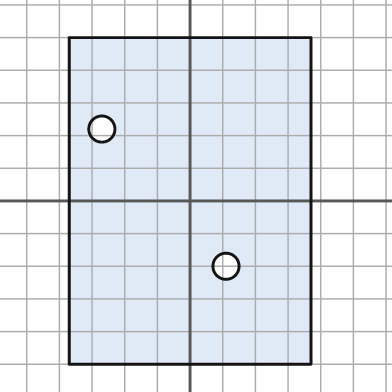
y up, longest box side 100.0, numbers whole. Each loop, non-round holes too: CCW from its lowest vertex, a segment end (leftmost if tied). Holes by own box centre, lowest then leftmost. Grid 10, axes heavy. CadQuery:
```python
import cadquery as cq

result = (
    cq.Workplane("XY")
    .moveTo(-37.0, -50.0)
    .lineTo(37.0, -50.0)
    .lineTo(37.0, 50.0)
    .lineTo(-37.0, 50.0)
    .close()
    .moveTo(11.0, -20.0)
    .circle(4.0)
    .moveTo(-27.0, 22.0)
    .circle(4.0)
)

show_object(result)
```